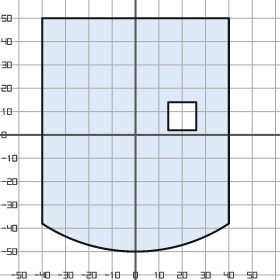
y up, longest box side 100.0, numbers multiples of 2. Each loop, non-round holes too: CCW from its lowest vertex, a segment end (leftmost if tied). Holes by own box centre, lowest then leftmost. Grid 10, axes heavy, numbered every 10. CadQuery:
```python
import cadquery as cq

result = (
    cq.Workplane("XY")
    .moveTo(-40.0, -38.0)
    .threePointArc((0.0, -50.0), (40.0, -38.0))
    .lineTo(40.0, 50.0)
    .lineTo(-40.0, 50.0)
    .close()
    .moveTo(14.0, 2.0)
    .lineTo(26.0, 2.0)
    .lineTo(26.0, 14.0)
    .lineTo(14.0, 14.0)
    .close()
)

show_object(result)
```